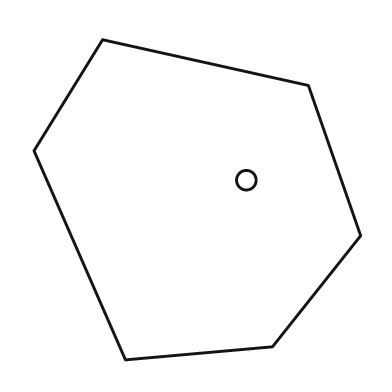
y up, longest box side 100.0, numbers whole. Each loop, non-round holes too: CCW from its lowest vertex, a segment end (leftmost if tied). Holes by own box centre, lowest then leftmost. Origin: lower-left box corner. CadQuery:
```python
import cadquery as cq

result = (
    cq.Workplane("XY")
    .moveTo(28.0, 0.0)
    .lineTo(73.0, 4.0)
    .lineTo(100.0, 38.0)
    .lineTo(84.0, 84.0)
    .lineTo(21.0, 98.0)
    .lineTo(0.0, 64.0)
    .close()
    .moveTo(65.0, 55.0)
    .circle(3.0)
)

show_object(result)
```